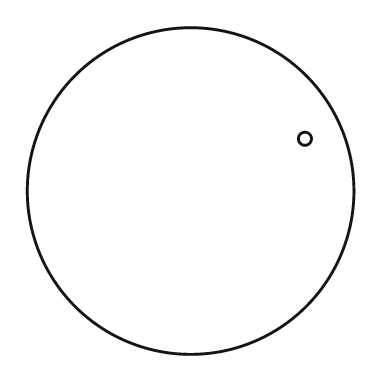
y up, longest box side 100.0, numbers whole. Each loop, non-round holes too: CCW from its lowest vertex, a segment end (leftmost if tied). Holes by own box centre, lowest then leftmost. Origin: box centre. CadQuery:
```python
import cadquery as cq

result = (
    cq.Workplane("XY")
    .moveTo(0.0, 0.0)
    .circle(50.0)
    .moveTo(35.0, 16.0)
    .circle(2.0)
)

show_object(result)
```